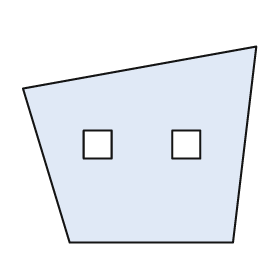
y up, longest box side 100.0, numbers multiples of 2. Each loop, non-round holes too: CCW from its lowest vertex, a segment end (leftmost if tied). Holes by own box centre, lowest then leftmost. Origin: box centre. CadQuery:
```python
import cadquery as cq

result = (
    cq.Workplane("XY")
    .moveTo(-30.0, -42.0)
    .lineTo(40.0, -42.0)
    .lineTo(50.0, 42.0)
    .lineTo(-50.0, 24.0)
    .close()
    .moveTo(-24.0, -6.0)
    .lineTo(-12.0, -6.0)
    .lineTo(-12.0, 6.0)
    .lineTo(-24.0, 6.0)
    .close()
    .moveTo(14.0, -6.0)
    .lineTo(26.0, -6.0)
    .lineTo(26.0, 6.0)
    .lineTo(14.0, 6.0)
    .close()
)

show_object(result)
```